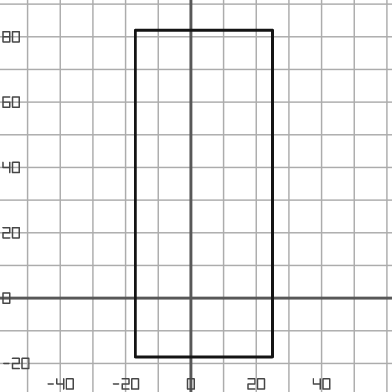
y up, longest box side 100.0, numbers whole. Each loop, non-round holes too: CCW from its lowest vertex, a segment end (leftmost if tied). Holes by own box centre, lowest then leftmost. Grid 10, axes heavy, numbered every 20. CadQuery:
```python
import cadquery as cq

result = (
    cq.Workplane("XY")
    .moveTo(-17.0, -18.0)
    .lineTo(25.0, -18.0)
    .lineTo(25.0, 82.0)
    .lineTo(-17.0, 82.0)
    .close()
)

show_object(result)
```